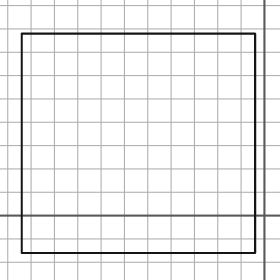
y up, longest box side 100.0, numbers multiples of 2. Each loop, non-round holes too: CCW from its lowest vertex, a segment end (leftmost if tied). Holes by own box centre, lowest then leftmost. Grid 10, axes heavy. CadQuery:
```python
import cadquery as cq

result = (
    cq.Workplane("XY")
    .moveTo(-104.0, -16.0)
    .lineTo(-4.0, -16.0)
    .lineTo(-4.0, 78.0)
    .lineTo(-104.0, 78.0)
    .close()
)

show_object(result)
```